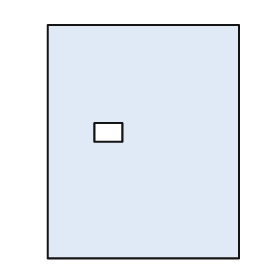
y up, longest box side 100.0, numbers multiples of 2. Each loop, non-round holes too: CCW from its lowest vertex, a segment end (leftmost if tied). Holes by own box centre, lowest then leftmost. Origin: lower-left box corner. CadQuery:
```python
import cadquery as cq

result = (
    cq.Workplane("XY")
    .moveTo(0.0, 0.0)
    .lineTo(82.0, 0.0)
    .lineTo(82.0, 100.0)
    .lineTo(0.0, 100.0)
    .close()
    .moveTo(20.0, 50.0)
    .lineTo(32.0, 50.0)
    .lineTo(32.0, 58.0)
    .lineTo(20.0, 58.0)
    .close()
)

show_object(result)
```